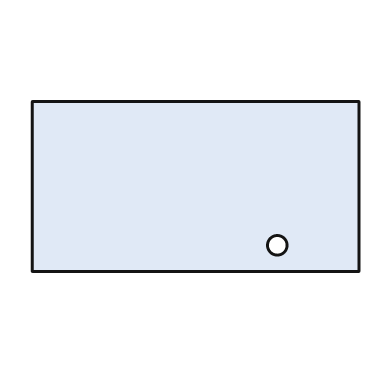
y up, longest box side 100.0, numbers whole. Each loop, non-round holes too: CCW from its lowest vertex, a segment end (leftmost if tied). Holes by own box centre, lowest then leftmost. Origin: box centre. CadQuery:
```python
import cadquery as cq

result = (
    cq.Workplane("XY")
    .moveTo(-50.0, -26.0)
    .lineTo(50.0, -26.0)
    .lineTo(50.0, 26.0)
    .lineTo(-50.0, 26.0)
    .close()
    .moveTo(25.0, -18.0)
    .circle(3.0)
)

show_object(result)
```